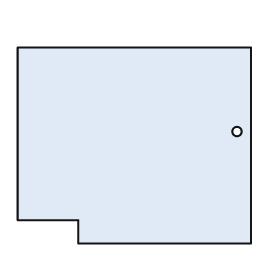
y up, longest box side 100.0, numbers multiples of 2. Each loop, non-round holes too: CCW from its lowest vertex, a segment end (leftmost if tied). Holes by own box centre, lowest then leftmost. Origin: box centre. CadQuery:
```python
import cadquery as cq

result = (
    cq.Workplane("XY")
    .moveTo(-24.0, -42.0)
    .lineTo(50.0, -42.0)
    .lineTo(50.0, 42.0)
    .lineTo(-50.0, 42.0)
    .lineTo(-50.0, -32.0)
    .lineTo(-24.0, -32.0)
    .close()
    .moveTo(44.0, 6.0)
    .circle(2.0)
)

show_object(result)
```